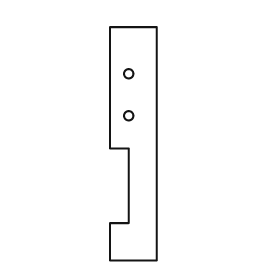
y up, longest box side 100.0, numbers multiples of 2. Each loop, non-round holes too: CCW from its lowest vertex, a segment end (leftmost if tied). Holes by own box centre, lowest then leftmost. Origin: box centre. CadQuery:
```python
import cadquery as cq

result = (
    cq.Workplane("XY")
    .moveTo(-10.0, -50.0)
    .lineTo(10.0, -50.0)
    .lineTo(10.0, 50.0)
    .lineTo(-10.0, 50.0)
    .lineTo(-10.0, -2.0)
    .lineTo(-2.0, -2.0)
    .lineTo(-2.0, -34.0)
    .lineTo(-10.0, -34.0)
    .close()
    .moveTo(-2.0, 12.0)
    .circle(2.0)
    .moveTo(-2.0, 30.0)
    .circle(2.0)
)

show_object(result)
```